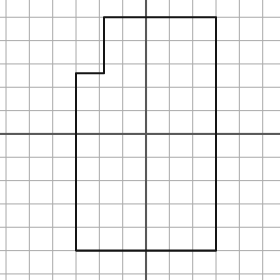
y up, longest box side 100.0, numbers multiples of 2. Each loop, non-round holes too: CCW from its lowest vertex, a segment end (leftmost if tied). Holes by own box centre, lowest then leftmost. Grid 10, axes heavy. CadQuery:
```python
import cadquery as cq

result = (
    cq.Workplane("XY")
    .moveTo(-30.0, -50.0)
    .lineTo(30.0, -50.0)
    .lineTo(30.0, 50.0)
    .lineTo(-18.0, 50.0)
    .lineTo(-18.0, 26.0)
    .lineTo(-30.0, 26.0)
    .close()
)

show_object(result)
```